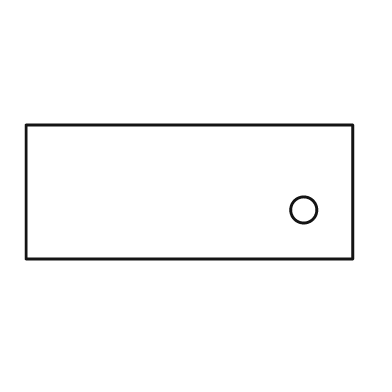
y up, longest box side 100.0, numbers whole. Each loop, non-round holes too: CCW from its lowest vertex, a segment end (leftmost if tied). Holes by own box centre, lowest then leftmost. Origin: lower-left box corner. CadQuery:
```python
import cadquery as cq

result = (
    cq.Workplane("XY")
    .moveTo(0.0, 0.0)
    .lineTo(100.0, 0.0)
    .lineTo(100.0, 41.0)
    .lineTo(0.0, 41.0)
    .close()
    .moveTo(85.0, 15.0)
    .circle(4.0)
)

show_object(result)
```